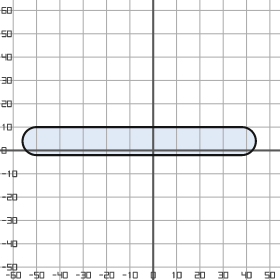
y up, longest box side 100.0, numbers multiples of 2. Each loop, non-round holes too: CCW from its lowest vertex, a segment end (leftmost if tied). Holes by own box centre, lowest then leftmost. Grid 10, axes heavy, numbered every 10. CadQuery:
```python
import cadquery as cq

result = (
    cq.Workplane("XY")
    .moveTo(-50.0, -2.0)
    .lineTo(38.0, -2.0)
    .threePointArc((44.0, 4.0), (38.0, 10.0))
    .lineTo(-50.0, 10.0)
    .threePointArc((-56.0, 4.0), (-50.0, -2.0))
    .close()
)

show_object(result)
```